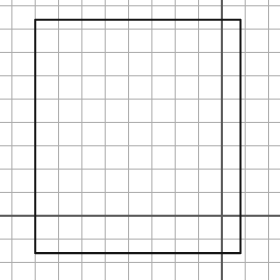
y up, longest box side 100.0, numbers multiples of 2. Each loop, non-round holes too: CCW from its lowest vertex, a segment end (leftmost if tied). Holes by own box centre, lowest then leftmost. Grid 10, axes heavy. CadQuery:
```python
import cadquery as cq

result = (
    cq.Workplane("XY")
    .moveTo(-80.0, -16.0)
    .lineTo(8.0, -16.0)
    .lineTo(8.0, 84.0)
    .lineTo(-80.0, 84.0)
    .close()
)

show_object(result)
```